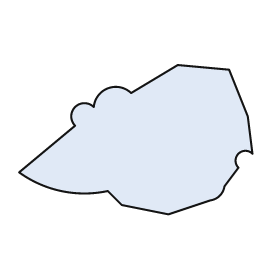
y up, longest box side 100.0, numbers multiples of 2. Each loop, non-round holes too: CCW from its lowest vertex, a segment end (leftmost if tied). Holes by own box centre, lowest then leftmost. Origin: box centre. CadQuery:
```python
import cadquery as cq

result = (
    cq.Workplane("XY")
    .moveTo(14.0, -32.0)
    .lineTo(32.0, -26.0)
    .threePointArc((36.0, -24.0), (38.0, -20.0))
    .lineTo(44.0, -12.0)
    .threePointArc((44.0, -6.0), (50.0, -6.0))
    .lineTo(48.0, 10.0)
    .lineTo(40.0, 30.0)
    .lineTo(18.0, 32.0)
    .lineTo(-2.0, 20.0)
    .threePointArc((-12.0, 22.0), (-18.0, 14.0))
    .threePointArc((-26.0, 14.0), (-26.0, 6.0))
    .lineTo(-50.0, -14.0)
    .threePointArc((-32.0, -22.0), (-12.0, -22.0))
    .lineTo(-6.0, -28.0)
    .close()
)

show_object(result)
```